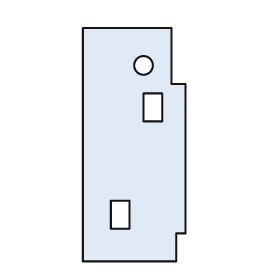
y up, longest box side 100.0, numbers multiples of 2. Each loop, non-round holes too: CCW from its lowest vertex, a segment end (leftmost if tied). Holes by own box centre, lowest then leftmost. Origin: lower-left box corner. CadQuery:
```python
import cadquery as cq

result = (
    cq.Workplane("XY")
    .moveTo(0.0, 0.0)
    .lineTo(40.0, 0.0)
    .lineTo(40.0, 12.0)
    .lineTo(44.0, 12.0)
    .lineTo(44.0, 76.0)
    .lineTo(38.0, 76.0)
    .lineTo(38.0, 100.0)
    .lineTo(0.0, 100.0)
    .close()
    .moveTo(12.0, 14.0)
    .lineTo(20.0, 14.0)
    .lineTo(20.0, 26.0)
    .lineTo(12.0, 26.0)
    .close()
    .moveTo(26.0, 60.0)
    .lineTo(34.0, 60.0)
    .lineTo(34.0, 72.0)
    .lineTo(26.0, 72.0)
    .close()
    .moveTo(26.0, 84.0)
    .circle(4.0)
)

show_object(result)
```